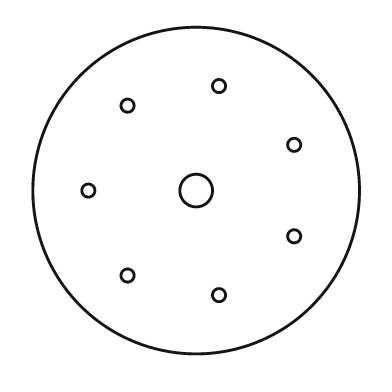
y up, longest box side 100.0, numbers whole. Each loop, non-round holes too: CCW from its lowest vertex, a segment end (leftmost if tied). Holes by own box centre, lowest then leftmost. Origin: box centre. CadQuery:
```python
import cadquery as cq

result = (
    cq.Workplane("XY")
    .moveTo(0.0, 0.0)
    .circle(50.0)
    .moveTo(7.0, -32.0)
    .circle(2.0)
    .moveTo(-21.0, -26.0)
    .circle(2.0)
    .moveTo(30.0, -14.0)
    .circle(2.0)
    .moveTo(-33.0, 0.0)
    .circle(2.0)
    .moveTo(0.0, 0.0)
    .circle(5.0)
    .moveTo(30.0, 14.0)
    .circle(2.0)
    .moveTo(-21.0, 26.0)
    .circle(2.0)
    .moveTo(7.0, 32.0)
    .circle(2.0)
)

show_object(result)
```